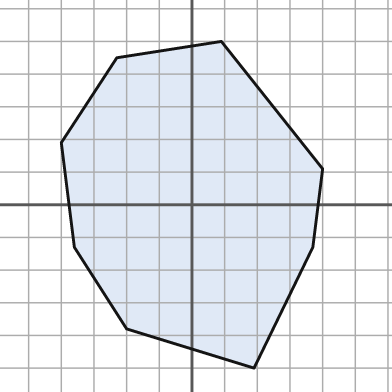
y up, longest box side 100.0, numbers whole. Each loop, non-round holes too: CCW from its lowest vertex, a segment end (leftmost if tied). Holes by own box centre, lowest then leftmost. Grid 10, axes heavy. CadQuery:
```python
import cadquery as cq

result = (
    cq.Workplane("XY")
    .moveTo(19.0, -50.0)
    .lineTo(37.0, -13.0)
    .lineTo(40.0, 11.0)
    .lineTo(9.0, 50.0)
    .lineTo(-23.0, 45.0)
    .lineTo(-40.0, 19.0)
    .lineTo(-36.0, -13.0)
    .lineTo(-20.0, -38.0)
    .close()
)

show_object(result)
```